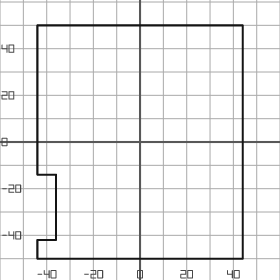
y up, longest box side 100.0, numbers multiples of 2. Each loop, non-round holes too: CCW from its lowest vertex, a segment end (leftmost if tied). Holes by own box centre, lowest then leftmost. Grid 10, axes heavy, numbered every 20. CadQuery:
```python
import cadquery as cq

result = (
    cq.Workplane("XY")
    .moveTo(-44.0, -50.0)
    .lineTo(44.0, -50.0)
    .lineTo(44.0, 50.0)
    .lineTo(-44.0, 50.0)
    .lineTo(-44.0, -14.0)
    .lineTo(-36.0, -14.0)
    .lineTo(-36.0, -42.0)
    .lineTo(-44.0, -42.0)
    .close()
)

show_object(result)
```